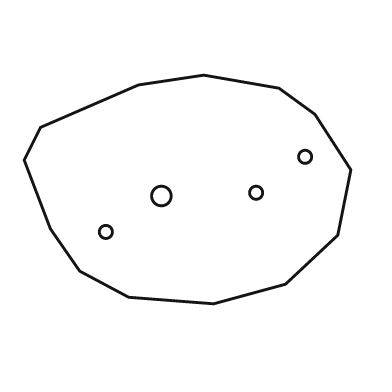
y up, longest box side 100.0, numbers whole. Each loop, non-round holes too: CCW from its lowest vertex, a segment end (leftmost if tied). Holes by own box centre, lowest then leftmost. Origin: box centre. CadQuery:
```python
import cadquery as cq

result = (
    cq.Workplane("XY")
    .moveTo(8.0, -35.0)
    .lineTo(30.0, -29.0)
    .lineTo(46.0, -14.0)
    .lineTo(50.0, 6.0)
    .lineTo(39.0, 23.0)
    .lineTo(28.0, 31.0)
    .lineTo(5.0, 35.0)
    .lineTo(-15.0, 32.0)
    .lineTo(-45.0, 19.0)
    .lineTo(-50.0, 9.0)
    .lineTo(-42.0, -12.0)
    .lineTo(-33.0, -25.0)
    .lineTo(-18.0, -33.0)
    .close()
    .moveTo(-25.0, -13.0)
    .circle(2.0)
    .moveTo(-8.0, -2.0)
    .circle(3.0)
    .moveTo(21.0, -1.0)
    .circle(2.0)
    .moveTo(36.0, 10.0)
    .circle(2.0)
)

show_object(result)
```